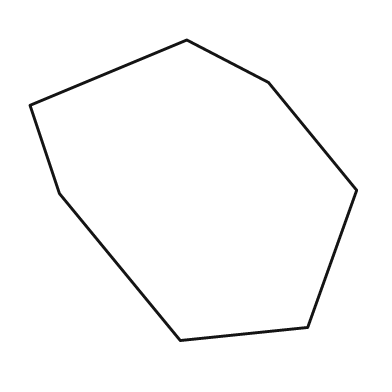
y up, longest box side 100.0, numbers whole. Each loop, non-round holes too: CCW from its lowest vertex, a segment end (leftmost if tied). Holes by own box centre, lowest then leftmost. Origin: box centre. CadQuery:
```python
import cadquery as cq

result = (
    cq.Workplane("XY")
    .moveTo(-4.0, -46.0)
    .lineTo(35.0, -42.0)
    .lineTo(50.0, 0.0)
    .lineTo(23.0, 33.0)
    .lineTo(-2.0, 46.0)
    .lineTo(-50.0, 26.0)
    .lineTo(-41.0, -1.0)
    .close()
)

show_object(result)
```